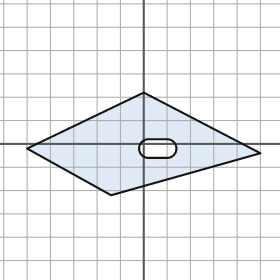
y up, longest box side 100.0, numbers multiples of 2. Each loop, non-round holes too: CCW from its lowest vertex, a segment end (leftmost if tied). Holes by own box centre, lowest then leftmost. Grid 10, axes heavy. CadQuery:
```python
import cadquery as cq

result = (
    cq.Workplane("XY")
    .moveTo(-14.0, -22.0)
    .lineTo(50.0, -4.0)
    .lineTo(0.0, 22.0)
    .lineTo(-50.0, -2.0)
    .close()
    .moveTo(2.0, -6.0)
    .lineTo(10.0, -6.0)
    .threePointArc((14.0, -2.0), (10.0, 2.0))
    .lineTo(2.0, 2.0)
    .threePointArc((-2.0, -2.0), (2.0, -6.0))
    .close()
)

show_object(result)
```